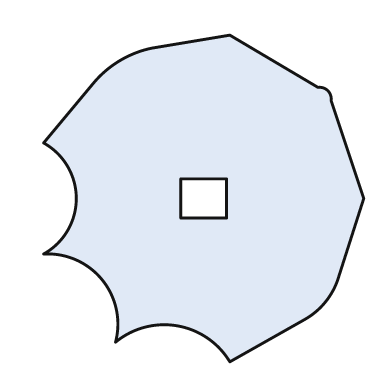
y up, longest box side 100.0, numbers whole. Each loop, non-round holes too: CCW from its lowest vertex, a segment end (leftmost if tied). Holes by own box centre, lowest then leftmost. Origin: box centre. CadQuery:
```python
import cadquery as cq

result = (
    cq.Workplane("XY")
    .moveTo(8.0, -50.0)
    .lineTo(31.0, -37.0)
    .threePointArc((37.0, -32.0), (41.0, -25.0))
    .lineTo(49.0, 0.0)
    .lineTo(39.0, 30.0)
    .threePointArc((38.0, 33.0), (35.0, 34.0))
    .lineTo(8.0, 50.0)
    .lineTo(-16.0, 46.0)
    .threePointArc((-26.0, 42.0), (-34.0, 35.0))
    .lineTo(-49.0, 17.0)
    .threePointArc((-39.0, 0.0), (-49.0, -17.0))
    .threePointArc((-31.0, -25.0), (-27.0, -44.0))
    .threePointArc((-8.0, -39.0), (8.0, -50.0))
    .close()
    .moveTo(-7.0, -6.0)
    .lineTo(7.0, -6.0)
    .lineTo(7.0, 6.0)
    .lineTo(-7.0, 6.0)
    .close()
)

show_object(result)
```